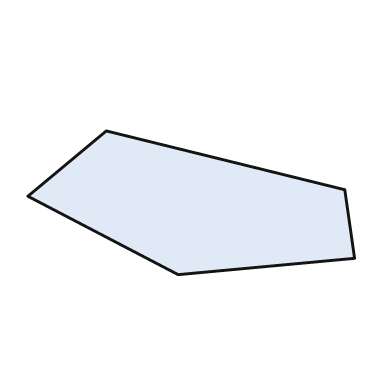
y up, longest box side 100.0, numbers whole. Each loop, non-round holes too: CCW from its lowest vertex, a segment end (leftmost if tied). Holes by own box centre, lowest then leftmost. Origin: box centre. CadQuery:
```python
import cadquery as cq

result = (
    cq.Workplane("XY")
    .moveTo(-4.0, -22.0)
    .lineTo(50.0, -17.0)
    .lineTo(47.0, 4.0)
    .lineTo(-26.0, 22.0)
    .lineTo(-50.0, 2.0)
    .close()
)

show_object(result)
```